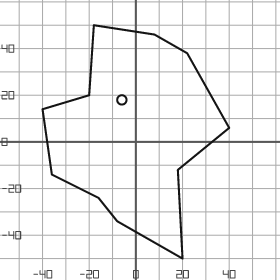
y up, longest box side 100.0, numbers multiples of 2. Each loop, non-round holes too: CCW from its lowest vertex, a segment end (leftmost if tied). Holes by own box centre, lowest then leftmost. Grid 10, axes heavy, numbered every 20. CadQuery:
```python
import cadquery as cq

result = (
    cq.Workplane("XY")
    .moveTo(20.0, -50.0)
    .lineTo(18.0, -12.0)
    .lineTo(40.0, 6.0)
    .lineTo(22.0, 38.0)
    .lineTo(8.0, 46.0)
    .lineTo(-18.0, 50.0)
    .lineTo(-20.0, 20.0)
    .lineTo(-40.0, 14.0)
    .lineTo(-36.0, -14.0)
    .lineTo(-16.0, -24.0)
    .lineTo(-8.0, -34.0)
    .close()
    .moveTo(-6.0, 18.0)
    .circle(2.0)
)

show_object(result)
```